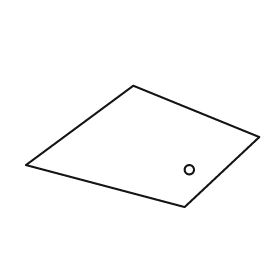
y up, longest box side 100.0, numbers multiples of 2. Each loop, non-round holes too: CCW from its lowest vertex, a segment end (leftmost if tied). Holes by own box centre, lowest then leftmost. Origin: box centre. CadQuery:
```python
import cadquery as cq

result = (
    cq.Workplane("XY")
    .moveTo(18.0, -26.0)
    .lineTo(50.0, 4.0)
    .lineTo(-4.0, 26.0)
    .lineTo(-50.0, -8.0)
    .close()
    .moveTo(20.0, -10.0)
    .circle(2.0)
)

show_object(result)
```